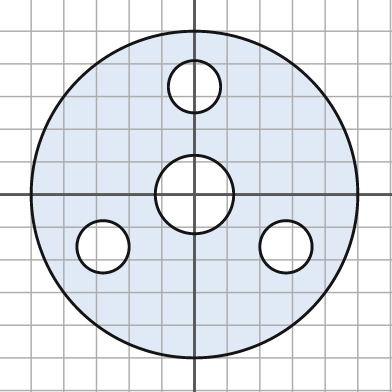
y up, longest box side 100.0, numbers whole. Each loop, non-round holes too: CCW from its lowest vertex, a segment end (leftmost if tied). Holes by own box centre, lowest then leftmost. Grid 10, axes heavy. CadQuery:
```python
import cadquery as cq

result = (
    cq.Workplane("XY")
    .moveTo(0.0, 0.0)
    .circle(50.0)
    .moveTo(-28.0, -16.0)
    .circle(8.0)
    .moveTo(28.0, -16.0)
    .circle(8.0)
    .moveTo(0.0, 0.0)
    .circle(12.0)
    .moveTo(0.0, 33.0)
    .circle(8.0)
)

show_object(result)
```